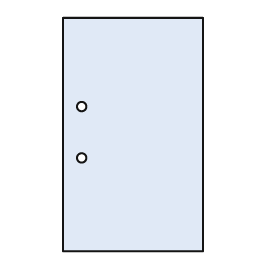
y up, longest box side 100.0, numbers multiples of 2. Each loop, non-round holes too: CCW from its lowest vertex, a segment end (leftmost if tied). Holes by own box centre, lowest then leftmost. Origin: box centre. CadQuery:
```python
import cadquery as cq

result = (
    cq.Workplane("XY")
    .moveTo(-30.0, -50.0)
    .lineTo(30.0, -50.0)
    .lineTo(30.0, 50.0)
    .lineTo(-30.0, 50.0)
    .close()
    .moveTo(-22.0, -10.0)
    .circle(2.0)
    .moveTo(-22.0, 12.0)
    .circle(2.0)
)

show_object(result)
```